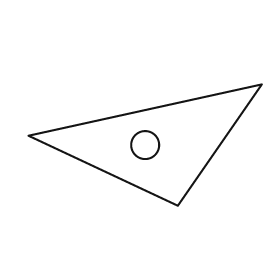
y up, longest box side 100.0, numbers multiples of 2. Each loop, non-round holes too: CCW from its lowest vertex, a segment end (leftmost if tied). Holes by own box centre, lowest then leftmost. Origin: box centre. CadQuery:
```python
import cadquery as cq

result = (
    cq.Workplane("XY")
    .moveTo(14.0, -26.0)
    .lineTo(50.0, 26.0)
    .lineTo(-50.0, 4.0)
    .close()
    .moveTo(0.0, 0.0)
    .circle(6.0)
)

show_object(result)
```